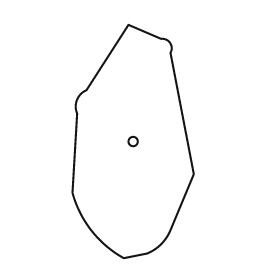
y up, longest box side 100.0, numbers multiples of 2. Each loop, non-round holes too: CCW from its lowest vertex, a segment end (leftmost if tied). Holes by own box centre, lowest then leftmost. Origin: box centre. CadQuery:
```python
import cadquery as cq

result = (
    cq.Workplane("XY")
    .moveTo(-4.0, -50.0)
    .lineTo(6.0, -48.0)
    .threePointArc((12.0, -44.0), (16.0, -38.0))
    .lineTo(26.0, -14.0)
    .lineTo(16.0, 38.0)
    .threePointArc((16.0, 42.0), (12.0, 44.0))
    .lineTo(-2.0, 50.0)
    .lineTo(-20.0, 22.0)
    .threePointArc((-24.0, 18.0), (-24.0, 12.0))
    .lineTo(-26.0, -22.0)
    .threePointArc((-18.0, -38.0), (-4.0, -50.0))
    .close()
    .moveTo(0.0, 0.0)
    .circle(2.0)
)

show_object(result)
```